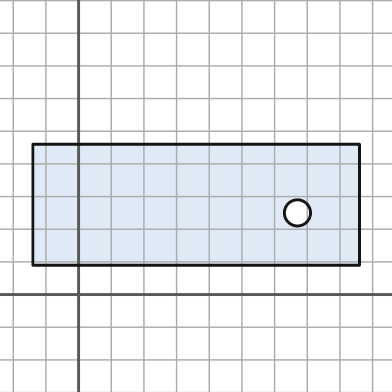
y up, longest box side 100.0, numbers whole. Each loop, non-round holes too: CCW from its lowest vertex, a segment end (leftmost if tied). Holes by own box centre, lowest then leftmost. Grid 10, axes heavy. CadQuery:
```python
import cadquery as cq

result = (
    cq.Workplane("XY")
    .moveTo(-14.0, 9.0)
    .lineTo(86.0, 9.0)
    .lineTo(86.0, 46.0)
    .lineTo(-14.0, 46.0)
    .close()
    .moveTo(67.0, 25.0)
    .circle(4.0)
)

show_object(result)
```